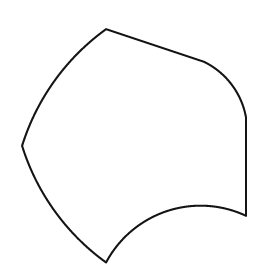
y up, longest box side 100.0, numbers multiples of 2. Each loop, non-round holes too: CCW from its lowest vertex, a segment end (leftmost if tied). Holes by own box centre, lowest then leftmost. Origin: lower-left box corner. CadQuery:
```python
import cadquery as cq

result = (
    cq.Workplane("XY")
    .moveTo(36.0, 0.0)
    .threePointArc((62.0, 22.0), (96.0, 20.0))
    .lineTo(96.0, 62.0)
    .threePointArc((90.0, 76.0), (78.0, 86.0))
    .lineTo(36.0, 100.0)
    .threePointArc((14.0, 78.0), (0.0, 50.0))
    .threePointArc((14.0, 22.0), (36.0, 0.0))
    .close()
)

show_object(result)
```